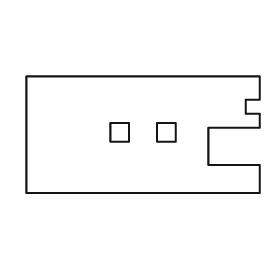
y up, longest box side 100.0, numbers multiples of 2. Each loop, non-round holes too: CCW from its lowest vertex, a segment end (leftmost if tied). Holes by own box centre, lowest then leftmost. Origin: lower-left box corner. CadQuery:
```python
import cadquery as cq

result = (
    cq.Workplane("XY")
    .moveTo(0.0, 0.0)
    .lineTo(100.0, 0.0)
    .lineTo(100.0, 12.0)
    .lineTo(78.0, 12.0)
    .lineTo(78.0, 28.0)
    .lineTo(100.0, 28.0)
    .lineTo(100.0, 34.0)
    .lineTo(94.0, 34.0)
    .lineTo(94.0, 40.0)
    .lineTo(100.0, 40.0)
    .lineTo(100.0, 50.0)
    .lineTo(0.0, 50.0)
    .close()
    .moveTo(36.0, 22.0)
    .lineTo(44.0, 22.0)
    .lineTo(44.0, 30.0)
    .lineTo(36.0, 30.0)
    .close()
    .moveTo(56.0, 22.0)
    .lineTo(64.0, 22.0)
    .lineTo(64.0, 30.0)
    .lineTo(56.0, 30.0)
    .close()
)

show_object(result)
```